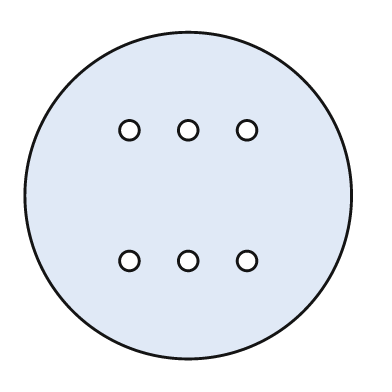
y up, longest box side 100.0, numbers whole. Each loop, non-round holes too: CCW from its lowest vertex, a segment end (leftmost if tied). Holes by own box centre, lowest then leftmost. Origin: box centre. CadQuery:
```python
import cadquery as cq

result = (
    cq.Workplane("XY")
    .moveTo(0.0, 0.0)
    .circle(50.0)
    .moveTo(-18.0, -20.0)
    .circle(3.0)
    .moveTo(0.0, -20.0)
    .circle(3.0)
    .moveTo(18.0, -20.0)
    .circle(3.0)
    .moveTo(-18.0, 20.0)
    .circle(3.0)
    .moveTo(0.0, 20.0)
    .circle(3.0)
    .moveTo(18.0, 20.0)
    .circle(3.0)
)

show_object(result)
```